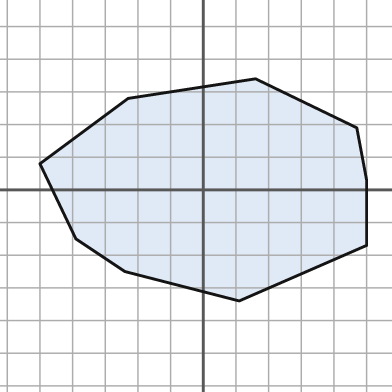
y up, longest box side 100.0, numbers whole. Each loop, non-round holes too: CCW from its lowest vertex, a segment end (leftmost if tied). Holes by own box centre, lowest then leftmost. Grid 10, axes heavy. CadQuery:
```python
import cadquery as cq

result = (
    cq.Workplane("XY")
    .moveTo(11.0, -34.0)
    .lineTo(50.0, -17.0)
    .lineTo(50.0, 3.0)
    .lineTo(47.0, 19.0)
    .lineTo(16.0, 34.0)
    .lineTo(-23.0, 28.0)
    .lineTo(-50.0, 8.0)
    .lineTo(-39.0, -15.0)
    .lineTo(-24.0, -25.0)
    .close()
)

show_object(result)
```